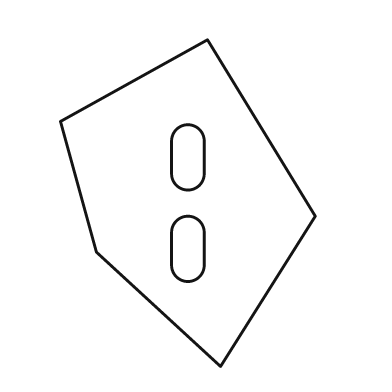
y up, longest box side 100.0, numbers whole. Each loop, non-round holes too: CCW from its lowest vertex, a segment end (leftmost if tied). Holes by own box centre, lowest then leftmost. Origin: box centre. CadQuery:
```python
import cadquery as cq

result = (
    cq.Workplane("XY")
    .moveTo(10.0, -50.0)
    .lineTo(39.0, -4.0)
    .lineTo(6.0, 50.0)
    .lineTo(-39.0, 25.0)
    .lineTo(-28.0, -15.0)
    .close()
    .moveTo(-5.0, -19.0)
    .threePointArc((0.0, -24.0), (5.0, -19.0))
    .lineTo(5.0, -9.0)
    .threePointArc((0.0, -4.0), (-5.0, -9.0))
    .close()
    .moveTo(-5.0, 9.0)
    .threePointArc((0.0, 4.0), (5.0, 9.0))
    .lineTo(5.0, 19.0)
    .threePointArc((0.0, 24.0), (-5.0, 19.0))
    .close()
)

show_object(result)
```